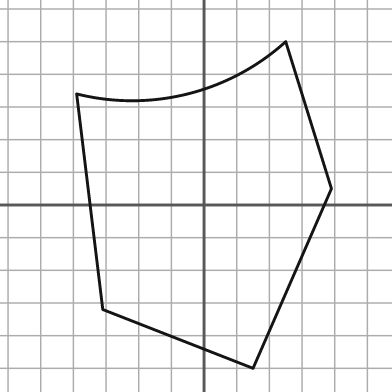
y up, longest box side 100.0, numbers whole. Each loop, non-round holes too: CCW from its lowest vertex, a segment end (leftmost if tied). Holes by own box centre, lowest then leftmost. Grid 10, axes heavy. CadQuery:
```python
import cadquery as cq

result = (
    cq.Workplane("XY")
    .moveTo(15.0, -50.0)
    .lineTo(39.0, 5.0)
    .lineTo(25.0, 50.0)
    .threePointArc((-5.0, 34.0), (-39.0, 34.0))
    .lineTo(-31.0, -32.0)
    .close()
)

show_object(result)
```